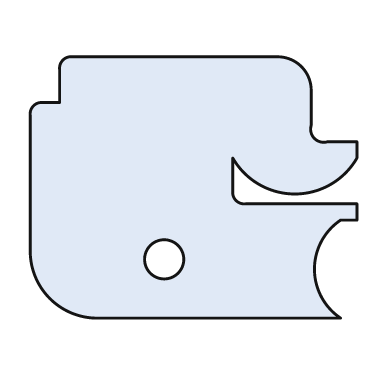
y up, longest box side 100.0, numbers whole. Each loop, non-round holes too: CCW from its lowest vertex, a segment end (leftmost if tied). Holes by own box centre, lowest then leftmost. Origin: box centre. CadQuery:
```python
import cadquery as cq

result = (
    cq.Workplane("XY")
    .moveTo(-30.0, -40.0)
    .lineTo(45.0, -40.0)
    .threePointArc((37.0, -25.0), (45.0, -10.0))
    .lineTo(50.0, -10.0)
    .lineTo(50.0, -5.0)
    .lineTo(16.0, -5.0)
    .threePointArc((13.0, -4.0), (12.0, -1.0))
    .lineTo(12.0, 9.0)
    .threePointArc((31.0, -2.0), (50.0, 9.0))
    .lineTo(50.0, 14.0)
    .lineTo(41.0, 14.0)
    .threePointArc((37.0, 15.0), (36.0, 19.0))
    .lineTo(36.0, 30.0)
    .threePointArc((33.0, 37.0), (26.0, 40.0))
    .lineTo(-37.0, 40.0)
    .threePointArc((-40.0, 39.0), (-41.0, 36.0))
    .lineTo(-41.0, 26.0)
    .lineTo(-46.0, 26.0)
    .threePointArc((-49.0, 25.0), (-50.0, 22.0))
    .lineTo(-50.0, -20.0)
    .threePointArc((-44.0, -34.0), (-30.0, -40.0))
    .close()
    .moveTo(-9.0, -22.0)
    .circle(6.0)
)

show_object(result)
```